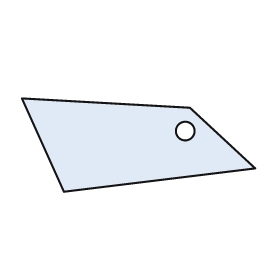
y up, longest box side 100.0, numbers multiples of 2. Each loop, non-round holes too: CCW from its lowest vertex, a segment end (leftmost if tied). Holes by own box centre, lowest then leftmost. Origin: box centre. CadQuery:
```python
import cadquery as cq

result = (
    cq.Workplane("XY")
    .moveTo(-32.0, -20.0)
    .lineTo(50.0, -10.0)
    .lineTo(22.0, 16.0)
    .lineTo(-50.0, 20.0)
    .close()
    .moveTo(20.0, 6.0)
    .circle(4.0)
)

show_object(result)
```